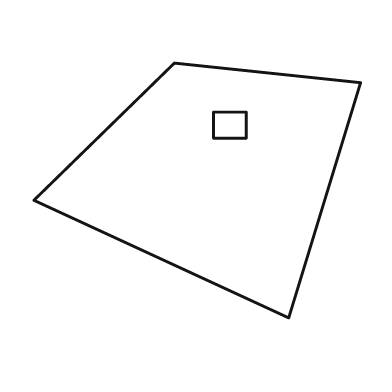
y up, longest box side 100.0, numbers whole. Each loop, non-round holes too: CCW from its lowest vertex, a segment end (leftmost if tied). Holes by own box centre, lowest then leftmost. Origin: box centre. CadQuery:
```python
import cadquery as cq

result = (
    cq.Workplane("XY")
    .moveTo(28.0, -39.0)
    .lineTo(50.0, 33.0)
    .lineTo(-7.0, 39.0)
    .lineTo(-50.0, -3.0)
    .close()
    .moveTo(5.0, 16.0)
    .lineTo(15.0, 16.0)
    .lineTo(15.0, 24.0)
    .lineTo(5.0, 24.0)
    .close()
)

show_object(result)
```